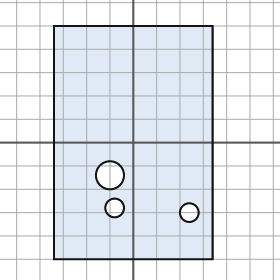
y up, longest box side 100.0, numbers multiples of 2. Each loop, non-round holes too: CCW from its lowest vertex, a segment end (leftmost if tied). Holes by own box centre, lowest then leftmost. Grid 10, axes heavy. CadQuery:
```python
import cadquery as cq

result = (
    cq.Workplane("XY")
    .moveTo(-34.0, -50.0)
    .lineTo(34.0, -50.0)
    .lineTo(34.0, 50.0)
    .lineTo(-34.0, 50.0)
    .close()
    .moveTo(24.0, -30.0)
    .circle(4.0)
    .moveTo(-8.0, -28.0)
    .circle(4.0)
    .moveTo(-10.0, -14.0)
    .circle(6.0)
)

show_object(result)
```